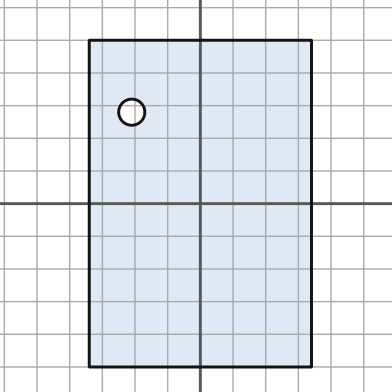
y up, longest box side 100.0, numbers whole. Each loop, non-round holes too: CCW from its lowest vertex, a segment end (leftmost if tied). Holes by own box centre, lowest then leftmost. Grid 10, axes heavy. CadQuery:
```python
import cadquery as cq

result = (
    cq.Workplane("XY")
    .moveTo(-34.0, -50.0)
    .lineTo(34.0, -50.0)
    .lineTo(34.0, 50.0)
    .lineTo(-34.0, 50.0)
    .close()
    .moveTo(-21.0, 28.0)
    .circle(4.0)
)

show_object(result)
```